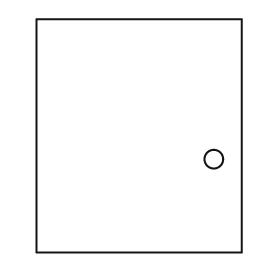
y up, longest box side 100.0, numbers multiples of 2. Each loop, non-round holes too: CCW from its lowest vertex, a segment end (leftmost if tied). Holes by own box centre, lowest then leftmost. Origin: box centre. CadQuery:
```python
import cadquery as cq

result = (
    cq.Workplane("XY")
    .moveTo(-44.0, -50.0)
    .lineTo(44.0, -50.0)
    .lineTo(44.0, 50.0)
    .lineTo(-44.0, 50.0)
    .close()
    .moveTo(32.0, -10.0)
    .circle(4.0)
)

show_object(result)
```